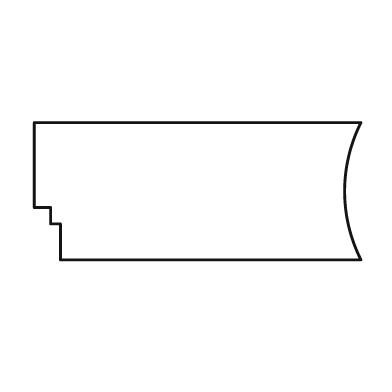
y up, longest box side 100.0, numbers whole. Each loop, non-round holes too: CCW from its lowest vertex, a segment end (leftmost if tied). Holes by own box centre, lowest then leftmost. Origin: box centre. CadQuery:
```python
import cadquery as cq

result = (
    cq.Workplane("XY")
    .moveTo(-42.0, -21.0)
    .lineTo(50.0, -21.0)
    .threePointArc((45.0, 0.0), (50.0, 21.0))
    .lineTo(-50.0, 21.0)
    .lineTo(-50.0, -5.0)
    .lineTo(-45.0, -5.0)
    .lineTo(-45.0, -10.0)
    .lineTo(-42.0, -10.0)
    .close()
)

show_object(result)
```